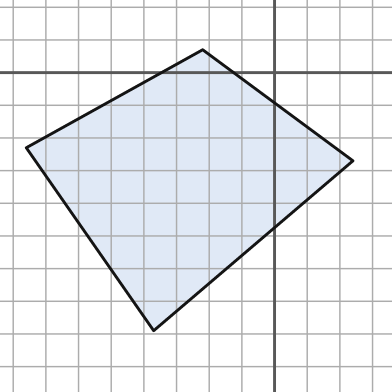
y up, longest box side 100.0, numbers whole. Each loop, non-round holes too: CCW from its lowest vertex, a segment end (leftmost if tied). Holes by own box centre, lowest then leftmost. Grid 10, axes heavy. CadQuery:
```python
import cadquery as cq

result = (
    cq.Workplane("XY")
    .moveTo(-37.0, -79.0)
    .lineTo(24.0, -27.0)
    .lineTo(-22.0, 7.0)
    .lineTo(-76.0, -23.0)
    .close()
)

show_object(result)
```